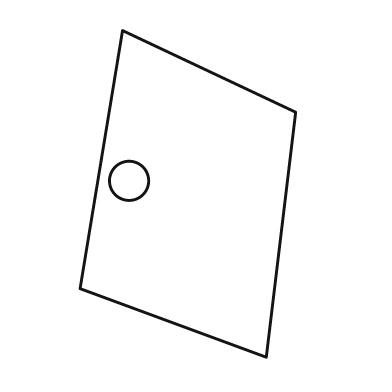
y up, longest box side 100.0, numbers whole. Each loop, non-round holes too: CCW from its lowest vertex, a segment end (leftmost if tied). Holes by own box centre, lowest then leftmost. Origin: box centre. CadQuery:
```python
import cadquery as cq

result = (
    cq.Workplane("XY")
    .moveTo(24.0, -50.0)
    .lineTo(33.0, 25.0)
    .lineTo(-20.0, 50.0)
    .lineTo(-33.0, -29.0)
    .close()
    .moveTo(-18.0, 4.0)
    .circle(6.0)
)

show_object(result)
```